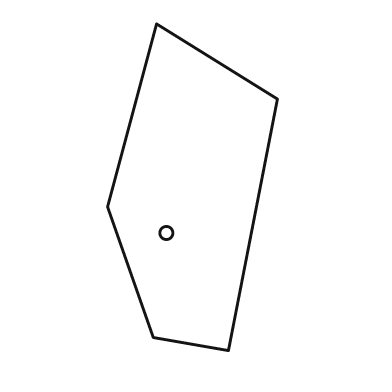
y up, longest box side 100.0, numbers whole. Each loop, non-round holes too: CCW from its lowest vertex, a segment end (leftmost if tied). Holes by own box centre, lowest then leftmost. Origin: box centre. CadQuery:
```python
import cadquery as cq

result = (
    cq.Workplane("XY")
    .moveTo(11.0, -50.0)
    .lineTo(26.0, 27.0)
    .lineTo(-11.0, 50.0)
    .lineTo(-26.0, -6.0)
    .lineTo(-12.0, -46.0)
    .close()
    .moveTo(-8.0, -14.0)
    .circle(2.0)
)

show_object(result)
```